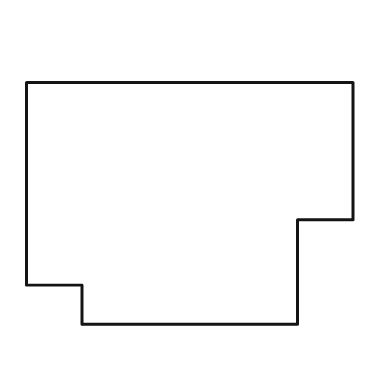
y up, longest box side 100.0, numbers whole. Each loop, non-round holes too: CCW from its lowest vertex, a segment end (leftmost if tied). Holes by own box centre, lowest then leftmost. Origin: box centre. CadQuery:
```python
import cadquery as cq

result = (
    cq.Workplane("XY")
    .moveTo(-33.0, -37.0)
    .lineTo(33.0, -37.0)
    .lineTo(33.0, -5.0)
    .lineTo(50.0, -5.0)
    .lineTo(50.0, 37.0)
    .lineTo(-50.0, 37.0)
    .lineTo(-50.0, -25.0)
    .lineTo(-33.0, -25.0)
    .close()
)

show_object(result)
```